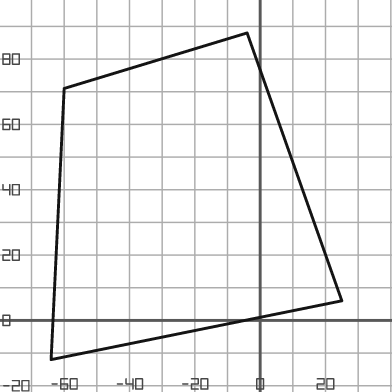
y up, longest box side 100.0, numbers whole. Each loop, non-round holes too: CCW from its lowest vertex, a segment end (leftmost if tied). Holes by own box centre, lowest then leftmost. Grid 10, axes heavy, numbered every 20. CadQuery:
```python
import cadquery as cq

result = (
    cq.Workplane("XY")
    .moveTo(-64.0, -12.0)
    .lineTo(25.0, 6.0)
    .lineTo(-4.0, 88.0)
    .lineTo(-60.0, 71.0)
    .close()
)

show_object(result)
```